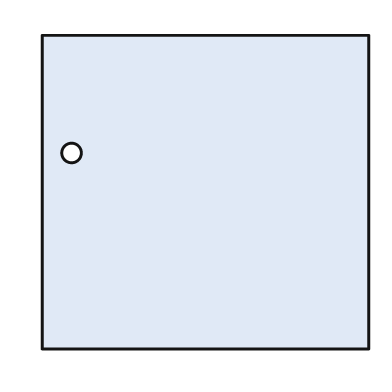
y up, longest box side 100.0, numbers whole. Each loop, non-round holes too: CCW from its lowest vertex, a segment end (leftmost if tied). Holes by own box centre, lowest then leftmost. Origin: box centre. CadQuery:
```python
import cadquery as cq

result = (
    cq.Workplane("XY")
    .moveTo(-50.0, -48.0)
    .lineTo(50.0, -48.0)
    .lineTo(50.0, 48.0)
    .lineTo(-50.0, 48.0)
    .close()
    .moveTo(-41.0, 12.0)
    .circle(3.0)
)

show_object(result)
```